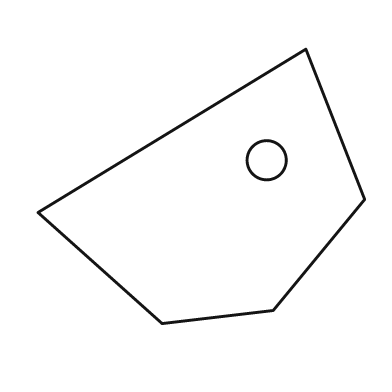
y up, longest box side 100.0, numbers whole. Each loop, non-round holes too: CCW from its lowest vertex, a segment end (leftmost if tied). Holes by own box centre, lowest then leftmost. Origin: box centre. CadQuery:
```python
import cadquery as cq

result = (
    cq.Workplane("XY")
    .moveTo(-12.0, -42.0)
    .lineTo(22.0, -38.0)
    .lineTo(50.0, -4.0)
    .lineTo(32.0, 42.0)
    .lineTo(-50.0, -8.0)
    .close()
    .moveTo(20.0, 8.0)
    .circle(6.0)
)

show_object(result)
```